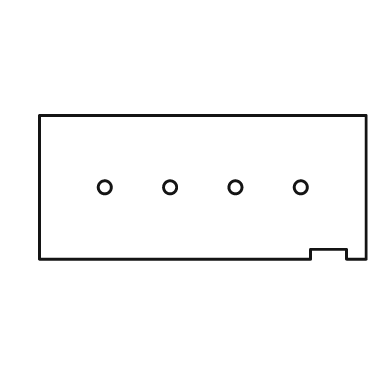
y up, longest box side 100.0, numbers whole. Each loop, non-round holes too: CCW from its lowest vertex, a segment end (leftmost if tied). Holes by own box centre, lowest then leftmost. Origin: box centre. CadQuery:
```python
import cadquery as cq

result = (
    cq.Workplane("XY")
    .moveTo(-50.0, -22.0)
    .lineTo(33.0, -22.0)
    .lineTo(33.0, -19.0)
    .lineTo(44.0, -19.0)
    .lineTo(44.0, -22.0)
    .lineTo(50.0, -22.0)
    .lineTo(50.0, 22.0)
    .lineTo(-50.0, 22.0)
    .close()
    .moveTo(-30.0, 0.0)
    .circle(2.0)
    .moveTo(-10.0, 0.0)
    .circle(2.0)
    .moveTo(10.0, 0.0)
    .circle(2.0)
    .moveTo(30.0, 0.0)
    .circle(2.0)
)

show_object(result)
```